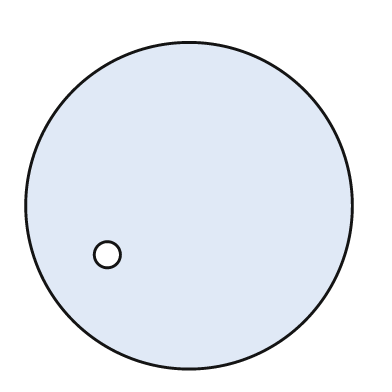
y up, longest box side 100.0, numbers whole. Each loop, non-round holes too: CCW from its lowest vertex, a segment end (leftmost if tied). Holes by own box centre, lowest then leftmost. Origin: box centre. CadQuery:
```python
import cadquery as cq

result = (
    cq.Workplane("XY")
    .moveTo(0.0, 0.0)
    .circle(50.0)
    .moveTo(-25.0, -15.0)
    .circle(4.0)
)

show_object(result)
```